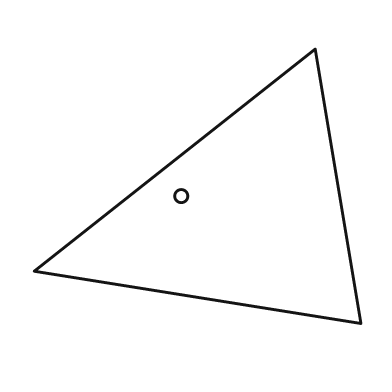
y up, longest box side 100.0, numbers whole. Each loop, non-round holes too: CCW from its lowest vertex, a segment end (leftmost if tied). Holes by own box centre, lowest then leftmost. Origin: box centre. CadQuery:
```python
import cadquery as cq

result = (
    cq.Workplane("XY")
    .moveTo(50.0, -42.0)
    .lineTo(36.0, 42.0)
    .lineTo(-50.0, -26.0)
    .close()
    .moveTo(-5.0, -3.0)
    .circle(2.0)
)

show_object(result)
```